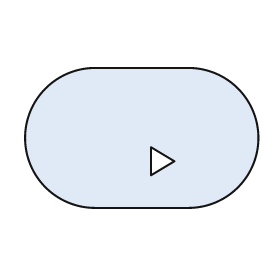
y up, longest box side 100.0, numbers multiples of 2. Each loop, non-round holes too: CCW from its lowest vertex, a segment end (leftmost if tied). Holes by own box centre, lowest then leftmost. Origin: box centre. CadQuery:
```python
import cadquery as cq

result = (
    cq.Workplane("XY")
    .moveTo(-20.0, -30.0)
    .lineTo(20.0, -30.0)
    .threePointArc((50.0, 0.0), (20.0, 30.0))
    .lineTo(-20.0, 30.0)
    .threePointArc((-50.0, 0.0), (-20.0, -30.0))
    .close()
    .moveTo(4.0, -16.0)
    .lineTo(14.0, -10.0)
    .lineTo(4.0, -4.0)
    .close()
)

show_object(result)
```